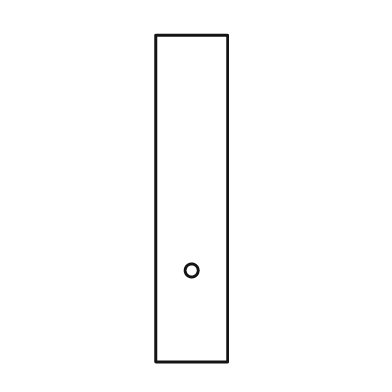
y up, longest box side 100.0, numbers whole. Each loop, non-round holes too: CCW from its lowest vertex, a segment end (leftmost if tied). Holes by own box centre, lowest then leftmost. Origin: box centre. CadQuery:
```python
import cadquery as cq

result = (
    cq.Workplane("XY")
    .moveTo(-11.0, -50.0)
    .lineTo(11.0, -50.0)
    .lineTo(11.0, 50.0)
    .lineTo(-11.0, 50.0)
    .close()
    .moveTo(0.0, -22.0)
    .circle(2.0)
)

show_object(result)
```